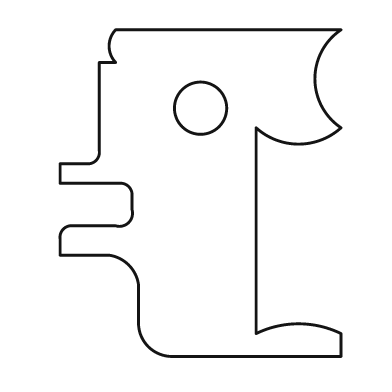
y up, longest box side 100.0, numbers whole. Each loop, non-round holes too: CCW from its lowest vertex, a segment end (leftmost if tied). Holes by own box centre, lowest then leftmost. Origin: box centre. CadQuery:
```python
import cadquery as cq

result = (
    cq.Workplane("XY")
    .moveTo(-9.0, -50.0)
    .lineTo(43.0, -50.0)
    .lineTo(43.0, -43.0)
    .threePointArc((30.0, -40.0), (17.0, -43.0))
    .lineTo(17.0, 20.0)
    .threePointArc((30.0, 15.0), (43.0, 20.0))
    .threePointArc((35.0, 35.0), (43.0, 50.0))
    .lineTo(-26.0, 50.0)
    .threePointArc((-28.0, 45.0), (-26.0, 40.0))
    .lineTo(-31.0, 40.0)
    .lineTo(-31.0, 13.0)
    .threePointArc((-32.0, 10.0), (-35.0, 9.0))
    .lineTo(-43.0, 9.0)
    .lineTo(-43.0, 3.0)
    .lineTo(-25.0, 3.0)
    .threePointArc((-22.0, 2.0), (-21.0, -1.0))
    .lineTo(-21.0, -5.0)
    .threePointArc((-22.0, -9.0), (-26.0, -10.0))
    .lineTo(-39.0, -10.0)
    .threePointArc((-42.0, -11.0), (-43.0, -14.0))
    .lineTo(-43.0, -19.0)
    .lineTo(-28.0, -19.0)
    .threePointArc((-22.0, -22.0), (-19.0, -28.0))
    .lineTo(-19.0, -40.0)
    .threePointArc((-16.0, -47.0), (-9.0, -50.0))
    .close()
    .moveTo(0.0, 26.0)
    .circle(8.0)
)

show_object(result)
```